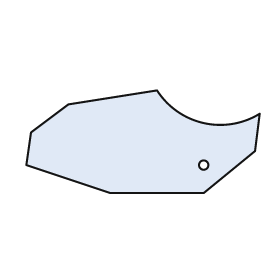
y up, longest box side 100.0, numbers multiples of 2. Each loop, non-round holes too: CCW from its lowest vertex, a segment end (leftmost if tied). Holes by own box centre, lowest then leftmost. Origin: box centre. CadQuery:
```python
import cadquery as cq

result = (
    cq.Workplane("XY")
    .moveTo(-14.0, -22.0)
    .lineTo(26.0, -22.0)
    .lineTo(48.0, -4.0)
    .lineTo(50.0, 12.0)
    .threePointArc((26.0, 8.0), (6.0, 22.0))
    .lineTo(-32.0, 16.0)
    .lineTo(-48.0, 4.0)
    .lineTo(-50.0, -10.0)
    .close()
    .moveTo(26.0, -10.0)
    .circle(2.0)
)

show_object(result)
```